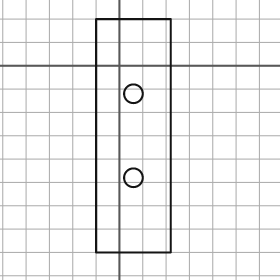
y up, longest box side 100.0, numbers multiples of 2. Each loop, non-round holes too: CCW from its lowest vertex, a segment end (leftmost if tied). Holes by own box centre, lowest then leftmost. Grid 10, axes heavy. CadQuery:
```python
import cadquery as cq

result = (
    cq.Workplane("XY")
    .moveTo(-10.0, -80.0)
    .lineTo(22.0, -80.0)
    .lineTo(22.0, 20.0)
    .lineTo(-10.0, 20.0)
    .close()
    .moveTo(6.0, -48.0)
    .circle(4.0)
    .moveTo(6.0, -12.0)
    .circle(4.0)
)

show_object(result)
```